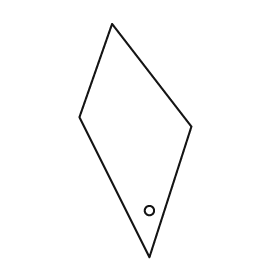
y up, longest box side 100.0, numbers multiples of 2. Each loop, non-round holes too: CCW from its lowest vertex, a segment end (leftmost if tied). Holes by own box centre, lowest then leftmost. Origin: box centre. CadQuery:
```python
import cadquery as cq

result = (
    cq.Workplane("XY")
    .moveTo(6.0, -50.0)
    .lineTo(24.0, 6.0)
    .lineTo(-10.0, 50.0)
    .lineTo(-24.0, 10.0)
    .close()
    .moveTo(6.0, -30.0)
    .circle(2.0)
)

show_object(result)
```